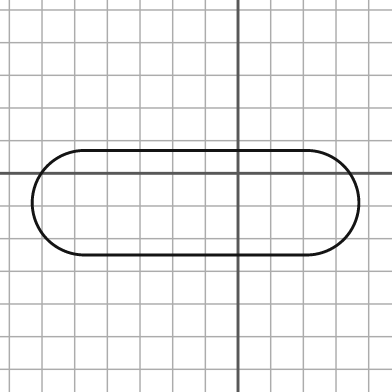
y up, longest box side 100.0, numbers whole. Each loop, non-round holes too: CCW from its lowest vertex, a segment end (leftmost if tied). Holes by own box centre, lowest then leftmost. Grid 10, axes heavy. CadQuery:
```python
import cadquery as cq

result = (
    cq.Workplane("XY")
    .moveTo(-47.0, -25.0)
    .lineTo(21.0, -25.0)
    .threePointArc((37.0, -9.0), (21.0, 7.0))
    .lineTo(-47.0, 7.0)
    .threePointArc((-63.0, -9.0), (-47.0, -25.0))
    .close()
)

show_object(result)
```